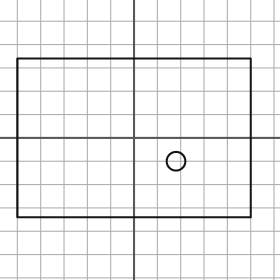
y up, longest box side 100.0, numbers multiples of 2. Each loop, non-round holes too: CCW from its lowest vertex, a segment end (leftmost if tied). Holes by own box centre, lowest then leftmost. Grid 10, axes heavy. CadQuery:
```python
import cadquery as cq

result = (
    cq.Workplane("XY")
    .moveTo(-50.0, -34.0)
    .lineTo(50.0, -34.0)
    .lineTo(50.0, 34.0)
    .lineTo(-50.0, 34.0)
    .close()
    .moveTo(18.0, -10.0)
    .circle(4.0)
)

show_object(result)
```